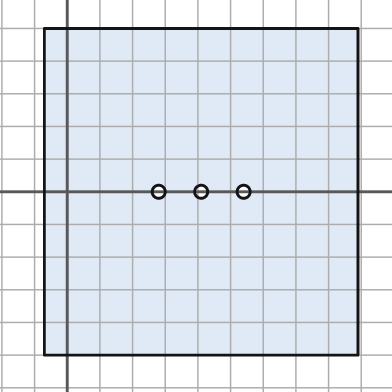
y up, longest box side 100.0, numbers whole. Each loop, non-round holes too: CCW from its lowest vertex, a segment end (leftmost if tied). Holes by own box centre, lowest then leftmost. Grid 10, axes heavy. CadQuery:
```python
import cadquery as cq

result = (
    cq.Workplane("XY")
    .moveTo(-7.0, -50.0)
    .lineTo(89.0, -50.0)
    .lineTo(89.0, 50.0)
    .lineTo(-7.0, 50.0)
    .close()
    .moveTo(28.0, 0.0)
    .circle(2.0)
    .moveTo(41.0, 0.0)
    .circle(2.0)
    .moveTo(54.0, 0.0)
    .circle(2.0)
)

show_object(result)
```